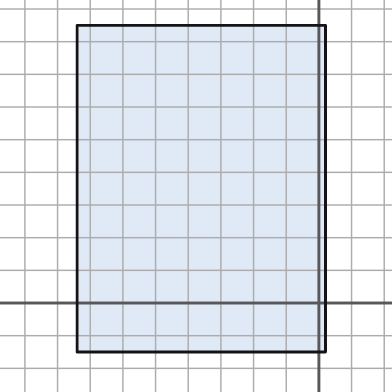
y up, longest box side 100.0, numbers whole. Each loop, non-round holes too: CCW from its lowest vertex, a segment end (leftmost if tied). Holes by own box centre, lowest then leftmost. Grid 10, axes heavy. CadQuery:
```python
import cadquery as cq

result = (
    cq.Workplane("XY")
    .moveTo(-74.0, -15.0)
    .lineTo(2.0, -15.0)
    .lineTo(2.0, 85.0)
    .lineTo(-74.0, 85.0)
    .close()
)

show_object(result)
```